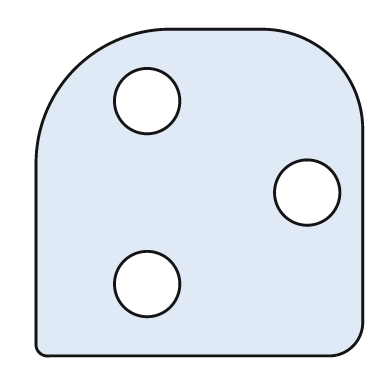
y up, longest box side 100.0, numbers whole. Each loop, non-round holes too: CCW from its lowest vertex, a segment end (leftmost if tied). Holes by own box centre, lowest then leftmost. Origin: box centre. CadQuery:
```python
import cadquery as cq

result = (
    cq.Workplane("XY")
    .moveTo(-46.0, -50.0)
    .lineTo(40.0, -50.0)
    .threePointArc((47.0, -47.0), (50.0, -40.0))
    .lineTo(50.0, 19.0)
    .threePointArc((41.0, 41.0), (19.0, 50.0))
    .lineTo(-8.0, 50.0)
    .threePointArc((-38.0, 38.0), (-50.0, 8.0))
    .lineTo(-50.0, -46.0)
    .threePointArc((-49.0, -49.0), (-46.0, -50.0))
    .close()
    .moveTo(-16.0, -28.0)
    .circle(10.0)
    .moveTo(33.0, 0.0)
    .circle(10.0)
    .moveTo(-16.0, 28.0)
    .circle(10.0)
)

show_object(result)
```